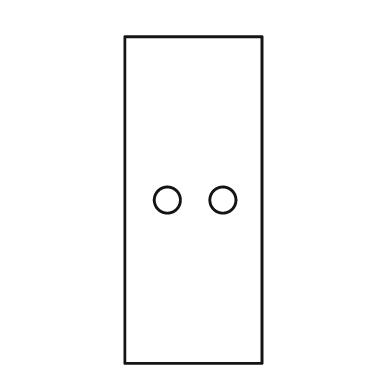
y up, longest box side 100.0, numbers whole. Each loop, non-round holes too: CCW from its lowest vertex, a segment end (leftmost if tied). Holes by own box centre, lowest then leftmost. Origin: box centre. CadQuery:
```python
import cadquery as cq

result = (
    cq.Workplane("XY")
    .moveTo(-21.0, -50.0)
    .lineTo(21.0, -50.0)
    .lineTo(21.0, 50.0)
    .lineTo(-21.0, 50.0)
    .close()
    .moveTo(-8.0, 0.0)
    .circle(4.0)
    .moveTo(9.0, 0.0)
    .circle(4.0)
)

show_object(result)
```